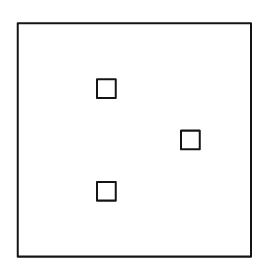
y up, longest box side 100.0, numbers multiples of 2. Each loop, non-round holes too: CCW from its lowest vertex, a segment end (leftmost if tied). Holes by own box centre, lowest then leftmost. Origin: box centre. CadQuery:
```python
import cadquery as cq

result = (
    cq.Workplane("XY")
    .moveTo(-50.0, -50.0)
    .lineTo(50.0, -50.0)
    .lineTo(50.0, 50.0)
    .lineTo(-50.0, 50.0)
    .close()
    .moveTo(-16.0, -26.0)
    .lineTo(-8.0, -26.0)
    .lineTo(-8.0, -18.0)
    .lineTo(-16.0, -18.0)
    .close()
    .moveTo(20.0, -4.0)
    .lineTo(28.0, -4.0)
    .lineTo(28.0, 4.0)
    .lineTo(20.0, 4.0)
    .close()
    .moveTo(-16.0, 18.0)
    .lineTo(-8.0, 18.0)
    .lineTo(-8.0, 26.0)
    .lineTo(-16.0, 26.0)
    .close()
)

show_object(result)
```